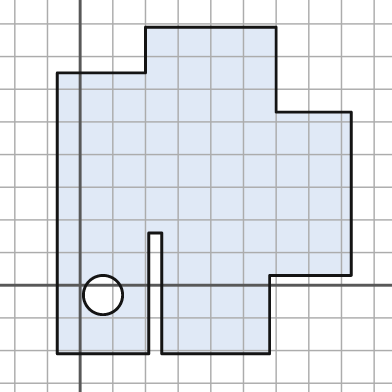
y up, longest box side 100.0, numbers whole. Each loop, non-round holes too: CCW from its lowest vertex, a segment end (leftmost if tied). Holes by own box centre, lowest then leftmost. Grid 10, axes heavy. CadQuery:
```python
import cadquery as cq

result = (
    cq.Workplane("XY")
    .moveTo(-7.0, -21.0)
    .lineTo(21.0, -21.0)
    .lineTo(21.0, 16.0)
    .lineTo(25.0, 16.0)
    .lineTo(25.0, -21.0)
    .lineTo(58.0, -21.0)
    .lineTo(58.0, 3.0)
    .lineTo(83.0, 3.0)
    .lineTo(83.0, 53.0)
    .lineTo(60.0, 53.0)
    .lineTo(60.0, 79.0)
    .lineTo(20.0, 79.0)
    .lineTo(20.0, 65.0)
    .lineTo(-7.0, 65.0)
    .close()
    .moveTo(7.0, -3.0)
    .circle(6.0)
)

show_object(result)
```